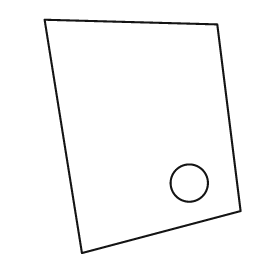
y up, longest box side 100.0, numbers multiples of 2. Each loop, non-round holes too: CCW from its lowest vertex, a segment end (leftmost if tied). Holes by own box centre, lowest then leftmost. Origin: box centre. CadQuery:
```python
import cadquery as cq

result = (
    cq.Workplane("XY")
    .moveTo(-26.0, -50.0)
    .lineTo(42.0, -32.0)
    .lineTo(32.0, 48.0)
    .lineTo(-42.0, 50.0)
    .close()
    .moveTo(20.0, -20.0)
    .circle(8.0)
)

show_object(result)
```